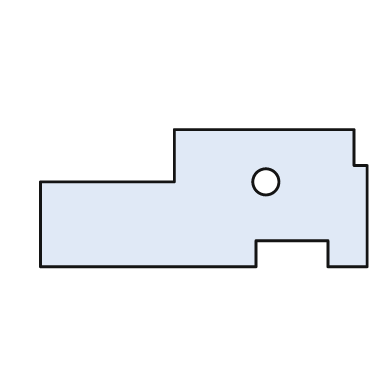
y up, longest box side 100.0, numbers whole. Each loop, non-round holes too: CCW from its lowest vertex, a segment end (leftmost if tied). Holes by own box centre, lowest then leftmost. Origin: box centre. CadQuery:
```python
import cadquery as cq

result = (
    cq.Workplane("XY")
    .moveTo(-50.0, -21.0)
    .lineTo(16.0, -21.0)
    .lineTo(16.0, -13.0)
    .lineTo(38.0, -13.0)
    .lineTo(38.0, -21.0)
    .lineTo(50.0, -21.0)
    .lineTo(50.0, 10.0)
    .lineTo(46.0, 10.0)
    .lineTo(46.0, 21.0)
    .lineTo(-9.0, 21.0)
    .lineTo(-9.0, 5.0)
    .lineTo(-50.0, 5.0)
    .close()
    .moveTo(19.0, 5.0)
    .circle(4.0)
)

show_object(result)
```